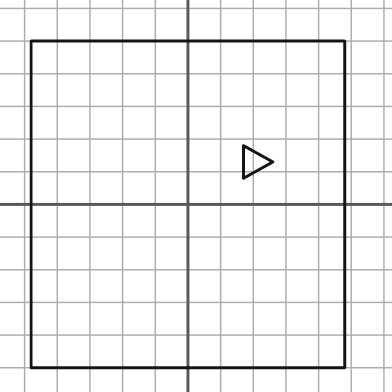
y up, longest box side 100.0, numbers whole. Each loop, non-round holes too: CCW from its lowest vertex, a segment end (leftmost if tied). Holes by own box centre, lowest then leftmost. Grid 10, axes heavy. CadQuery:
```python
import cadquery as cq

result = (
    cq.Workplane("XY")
    .moveTo(-48.0, -50.0)
    .lineTo(48.0, -50.0)
    .lineTo(48.0, 50.0)
    .lineTo(-48.0, 50.0)
    .close()
    .moveTo(17.0, 8.0)
    .lineTo(26.0, 13.0)
    .lineTo(17.0, 18.0)
    .close()
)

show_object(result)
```